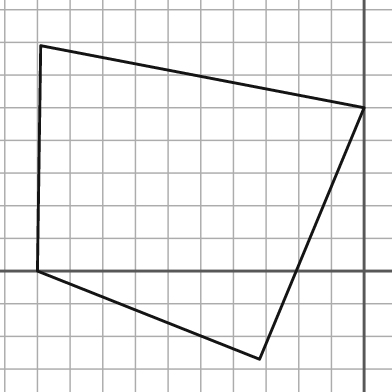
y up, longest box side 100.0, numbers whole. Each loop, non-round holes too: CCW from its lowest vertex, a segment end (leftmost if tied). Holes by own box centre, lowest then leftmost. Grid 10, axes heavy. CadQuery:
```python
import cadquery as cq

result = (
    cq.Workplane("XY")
    .moveTo(-32.0, -27.0)
    .lineTo(0.0, 50.0)
    .lineTo(-99.0, 69.0)
    .lineTo(-100.0, 0.0)
    .close()
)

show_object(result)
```